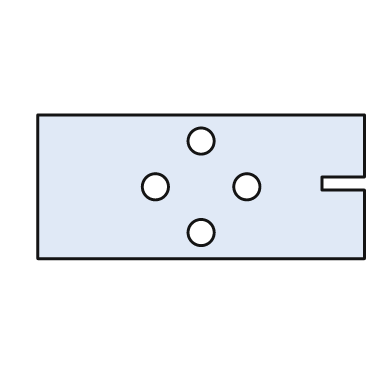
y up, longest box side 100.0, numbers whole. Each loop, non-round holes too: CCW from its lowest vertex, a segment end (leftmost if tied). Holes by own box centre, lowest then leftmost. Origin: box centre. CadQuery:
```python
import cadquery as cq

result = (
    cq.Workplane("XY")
    .moveTo(-50.0, -22.0)
    .lineTo(50.0, -22.0)
    .lineTo(50.0, -1.0)
    .lineTo(37.0, -1.0)
    .lineTo(37.0, 3.0)
    .lineTo(50.0, 3.0)
    .lineTo(50.0, 22.0)
    .lineTo(-50.0, 22.0)
    .close()
    .moveTo(0.0, -14.0)
    .circle(4.0)
    .moveTo(-14.0, 0.0)
    .circle(4.0)
    .moveTo(14.0, 0.0)
    .circle(4.0)
    .moveTo(0.0, 14.0)
    .circle(4.0)
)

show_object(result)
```